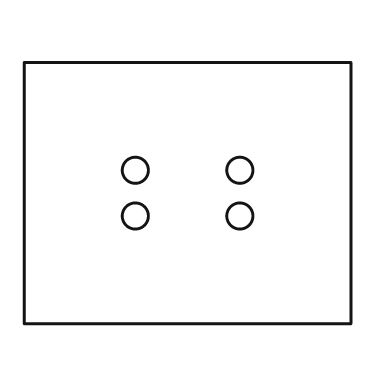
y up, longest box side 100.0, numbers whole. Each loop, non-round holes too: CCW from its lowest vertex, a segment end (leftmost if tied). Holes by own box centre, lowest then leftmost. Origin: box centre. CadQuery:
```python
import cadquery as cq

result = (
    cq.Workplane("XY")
    .moveTo(-50.0, -40.0)
    .lineTo(50.0, -40.0)
    .lineTo(50.0, 40.0)
    .lineTo(-50.0, 40.0)
    .close()
    .moveTo(-16.0, -7.0)
    .circle(4.0)
    .moveTo(16.0, -7.0)
    .circle(4.0)
    .moveTo(-16.0, 7.0)
    .circle(4.0)
    .moveTo(16.0, 7.0)
    .circle(4.0)
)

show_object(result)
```